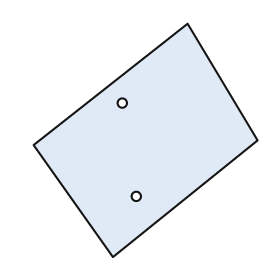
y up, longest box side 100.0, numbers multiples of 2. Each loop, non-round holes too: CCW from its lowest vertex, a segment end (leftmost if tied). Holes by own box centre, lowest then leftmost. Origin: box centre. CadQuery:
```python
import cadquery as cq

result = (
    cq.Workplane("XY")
    .moveTo(-14.0, -50.0)
    .lineTo(48.0, 0.0)
    .lineTo(18.0, 50.0)
    .lineTo(-48.0, -2.0)
    .close()
    .moveTo(-4.0, -24.0)
    .circle(2.0)
    .moveTo(-10.0, 16.0)
    .circle(2.0)
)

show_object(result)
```